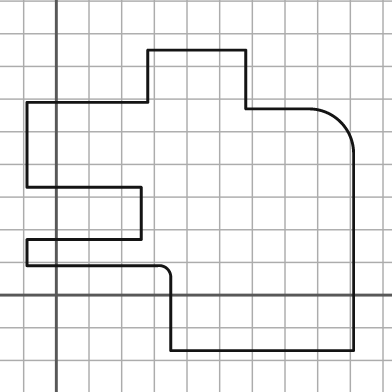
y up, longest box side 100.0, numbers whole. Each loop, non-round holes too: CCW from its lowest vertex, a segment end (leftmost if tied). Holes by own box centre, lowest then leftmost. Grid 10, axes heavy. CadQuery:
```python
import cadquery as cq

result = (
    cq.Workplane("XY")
    .moveTo(35.0, -17.0)
    .lineTo(91.0, -17.0)
    .lineTo(91.0, 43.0)
    .threePointArc((87.0, 53.0), (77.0, 57.0))
    .lineTo(58.0, 57.0)
    .lineTo(58.0, 75.0)
    .lineTo(28.0, 75.0)
    .lineTo(28.0, 59.0)
    .lineTo(-9.0, 59.0)
    .lineTo(-9.0, 33.0)
    .lineTo(26.0, 33.0)
    .lineTo(26.0, 17.0)
    .lineTo(-9.0, 17.0)
    .lineTo(-9.0, 9.0)
    .lineTo(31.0, 9.0)
    .threePointArc((34.0, 8.0), (35.0, 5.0))
    .close()
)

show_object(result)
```